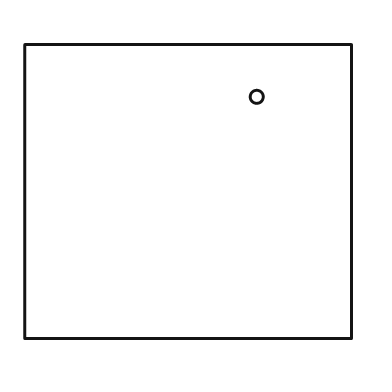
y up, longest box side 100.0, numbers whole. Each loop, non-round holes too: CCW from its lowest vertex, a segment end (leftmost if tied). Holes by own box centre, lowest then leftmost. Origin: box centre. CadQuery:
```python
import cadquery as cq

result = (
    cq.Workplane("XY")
    .moveTo(-50.0, -45.0)
    .lineTo(50.0, -45.0)
    .lineTo(50.0, 45.0)
    .lineTo(-50.0, 45.0)
    .close()
    .moveTo(21.0, 29.0)
    .circle(2.0)
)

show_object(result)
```